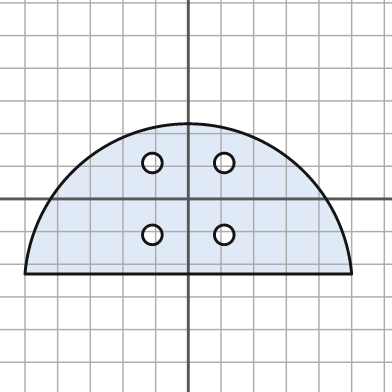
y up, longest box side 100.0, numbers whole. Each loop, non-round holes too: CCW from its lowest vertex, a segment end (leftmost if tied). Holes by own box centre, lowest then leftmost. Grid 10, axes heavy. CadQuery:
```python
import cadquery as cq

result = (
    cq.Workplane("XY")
    .moveTo(-50.0, -23.0)
    .lineTo(50.0, -23.0)
    .threePointArc((0.0, 23.0), (-50.0, -23.0))
    .close()
    .moveTo(-11.0, -11.0)
    .circle(3.0)
    .moveTo(11.0, -11.0)
    .circle(3.0)
    .moveTo(-11.0, 11.0)
    .circle(3.0)
    .moveTo(11.0, 11.0)
    .circle(3.0)
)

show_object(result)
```